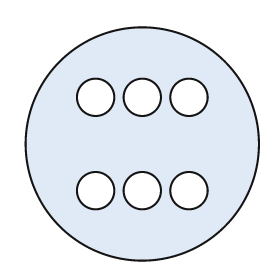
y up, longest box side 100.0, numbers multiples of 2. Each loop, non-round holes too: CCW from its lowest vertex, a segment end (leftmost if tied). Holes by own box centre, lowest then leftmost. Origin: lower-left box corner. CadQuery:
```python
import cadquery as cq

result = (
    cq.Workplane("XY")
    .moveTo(50.0, 50.0)
    .circle(50.0)
    .moveTo(30.0, 30.0)
    .circle(8.0)
    .moveTo(50.0, 30.0)
    .circle(8.0)
    .moveTo(70.0, 30.0)
    .circle(8.0)
    .moveTo(30.0, 70.0)
    .circle(8.0)
    .moveTo(50.0, 70.0)
    .circle(8.0)
    .moveTo(70.0, 70.0)
    .circle(8.0)
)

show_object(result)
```